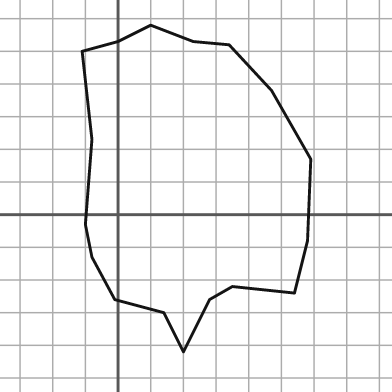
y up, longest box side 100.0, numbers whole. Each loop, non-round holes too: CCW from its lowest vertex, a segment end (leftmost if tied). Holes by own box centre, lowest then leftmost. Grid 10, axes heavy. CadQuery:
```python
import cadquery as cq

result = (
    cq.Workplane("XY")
    .moveTo(20.0, -42.0)
    .lineTo(28.0, -26.0)
    .lineTo(35.0, -22.0)
    .lineTo(54.0, -24.0)
    .lineTo(58.0, -8.0)
    .lineTo(59.0, 17.0)
    .lineTo(47.0, 38.0)
    .lineTo(34.0, 52.0)
    .lineTo(23.0, 53.0)
    .lineTo(10.0, 58.0)
    .lineTo(0.0, 53.0)
    .lineTo(-11.0, 50.0)
    .lineTo(-8.0, 23.0)
    .lineTo(-10.0, -3.0)
    .lineTo(-8.0, -13.0)
    .lineTo(-1.0, -26.0)
    .lineTo(14.0, -30.0)
    .close()
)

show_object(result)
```